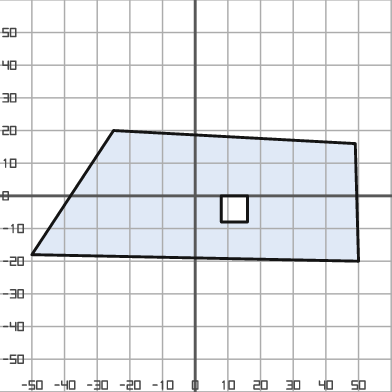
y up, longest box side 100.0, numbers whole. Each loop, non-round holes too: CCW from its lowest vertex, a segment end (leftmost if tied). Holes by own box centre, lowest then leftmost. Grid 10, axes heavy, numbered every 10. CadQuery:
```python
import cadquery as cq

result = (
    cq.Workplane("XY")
    .moveTo(50.0, -20.0)
    .lineTo(49.0, 16.0)
    .lineTo(-25.0, 20.0)
    .lineTo(-50.0, -18.0)
    .close()
    .moveTo(8.0, -8.0)
    .lineTo(16.0, -8.0)
    .lineTo(16.0, 0.0)
    .lineTo(8.0, 0.0)
    .close()
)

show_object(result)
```